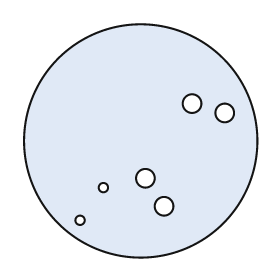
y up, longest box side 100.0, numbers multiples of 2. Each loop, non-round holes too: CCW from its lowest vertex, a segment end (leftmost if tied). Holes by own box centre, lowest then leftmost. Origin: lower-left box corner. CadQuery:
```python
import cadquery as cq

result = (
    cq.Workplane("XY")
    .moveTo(50.0, 50.0)
    .circle(50.0)
    .moveTo(24.0, 16.0)
    .circle(2.0)
    .moveTo(60.0, 22.0)
    .circle(4.0)
    .moveTo(34.0, 30.0)
    .circle(2.0)
    .moveTo(52.0, 34.0)
    .circle(4.0)
    .moveTo(86.0, 62.0)
    .circle(4.0)
    .moveTo(72.0, 66.0)
    .circle(4.0)
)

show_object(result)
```